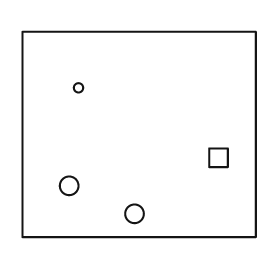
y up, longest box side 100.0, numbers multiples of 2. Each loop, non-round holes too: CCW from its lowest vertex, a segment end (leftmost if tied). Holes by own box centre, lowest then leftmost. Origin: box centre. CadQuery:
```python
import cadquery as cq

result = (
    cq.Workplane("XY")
    .moveTo(-50.0, -44.0)
    .lineTo(50.0, -44.0)
    .lineTo(50.0, 44.0)
    .lineTo(-50.0, 44.0)
    .close()
    .moveTo(-2.0, -34.0)
    .circle(4.0)
    .moveTo(-30.0, -22.0)
    .circle(4.0)
    .moveTo(30.0, -14.0)
    .lineTo(38.0, -14.0)
    .lineTo(38.0, -6.0)
    .lineTo(30.0, -6.0)
    .close()
    .moveTo(-26.0, 20.0)
    .circle(2.0)
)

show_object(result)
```